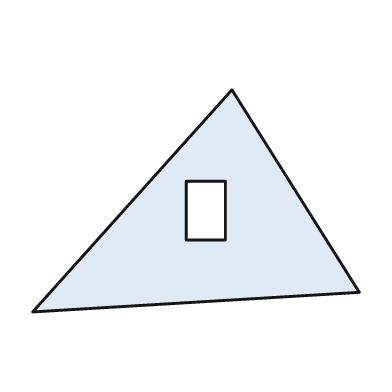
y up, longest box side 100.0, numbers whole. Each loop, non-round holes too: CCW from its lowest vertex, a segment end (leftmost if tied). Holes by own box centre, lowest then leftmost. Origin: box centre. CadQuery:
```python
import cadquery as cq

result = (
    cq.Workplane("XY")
    .moveTo(-50.0, -34.0)
    .lineTo(50.0, -28.0)
    .lineTo(11.0, 34.0)
    .close()
    .moveTo(-3.0, -12.0)
    .lineTo(9.0, -12.0)
    .lineTo(9.0, 6.0)
    .lineTo(-3.0, 6.0)
    .close()
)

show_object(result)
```